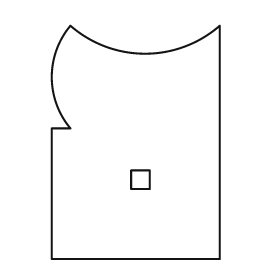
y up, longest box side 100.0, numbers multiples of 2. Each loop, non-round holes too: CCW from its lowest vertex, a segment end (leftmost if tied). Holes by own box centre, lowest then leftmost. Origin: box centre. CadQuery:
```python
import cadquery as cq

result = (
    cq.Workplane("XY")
    .moveTo(-36.0, -50.0)
    .lineTo(36.0, -50.0)
    .lineTo(36.0, 50.0)
    .threePointArc((4.0, 38.0), (-28.0, 50.0))
    .threePointArc((-36.0, 28.0), (-28.0, 6.0))
    .lineTo(-36.0, 6.0)
    .close()
    .moveTo(-2.0, -20.0)
    .lineTo(6.0, -20.0)
    .lineTo(6.0, -12.0)
    .lineTo(-2.0, -12.0)
    .close()
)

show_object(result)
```